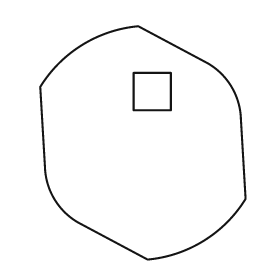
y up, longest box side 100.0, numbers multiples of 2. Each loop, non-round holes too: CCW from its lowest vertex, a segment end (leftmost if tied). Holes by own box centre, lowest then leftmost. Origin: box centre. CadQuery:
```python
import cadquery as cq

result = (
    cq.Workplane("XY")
    .moveTo(2.0, -50.0)
    .threePointArc((26.0, -42.0), (44.0, -24.0))
    .lineTo(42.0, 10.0)
    .threePointArc((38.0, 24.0), (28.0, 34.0))
    .lineTo(-2.0, 50.0)
    .threePointArc((-26.0, 42.0), (-44.0, 24.0))
    .lineTo(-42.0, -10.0)
    .threePointArc((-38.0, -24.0), (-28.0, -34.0))
    .close()
    .moveTo(-4.0, 14.0)
    .lineTo(12.0, 14.0)
    .lineTo(12.0, 30.0)
    .lineTo(-4.0, 30.0)
    .close()
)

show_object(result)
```